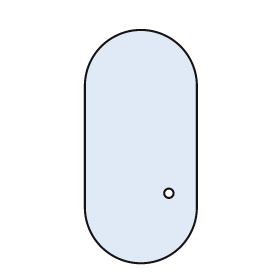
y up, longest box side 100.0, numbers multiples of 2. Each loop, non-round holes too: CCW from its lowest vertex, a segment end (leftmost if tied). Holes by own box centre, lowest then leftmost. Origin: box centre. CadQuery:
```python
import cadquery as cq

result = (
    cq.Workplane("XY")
    .moveTo(-24.0, -26.0)
    .threePointArc((0.0, -50.0), (24.0, -26.0))
    .lineTo(24.0, 26.0)
    .threePointArc((0.0, 50.0), (-24.0, 26.0))
    .close()
    .moveTo(12.0, -20.0)
    .circle(2.0)
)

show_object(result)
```